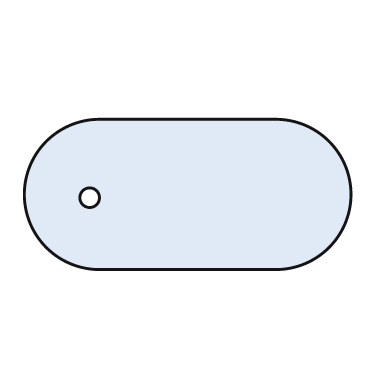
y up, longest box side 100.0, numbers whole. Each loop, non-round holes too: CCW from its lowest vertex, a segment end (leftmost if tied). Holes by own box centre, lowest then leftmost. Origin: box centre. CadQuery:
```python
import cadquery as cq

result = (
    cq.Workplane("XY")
    .moveTo(-27.0, -23.0)
    .lineTo(27.0, -23.0)
    .threePointArc((50.0, 0.0), (27.0, 23.0))
    .lineTo(-27.0, 23.0)
    .threePointArc((-50.0, 0.0), (-27.0, -23.0))
    .close()
    .moveTo(-30.0, -1.0)
    .circle(3.0)
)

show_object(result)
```